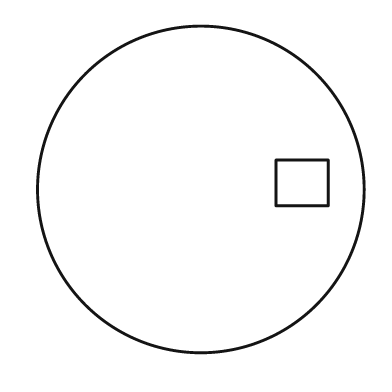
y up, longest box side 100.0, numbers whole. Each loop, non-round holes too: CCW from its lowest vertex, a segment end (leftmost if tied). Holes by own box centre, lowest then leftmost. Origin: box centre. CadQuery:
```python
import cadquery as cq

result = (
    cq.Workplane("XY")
    .moveTo(0.0, 0.0)
    .circle(50.0)
    .moveTo(23.0, -5.0)
    .lineTo(39.0, -5.0)
    .lineTo(39.0, 9.0)
    .lineTo(23.0, 9.0)
    .close()
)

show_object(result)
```